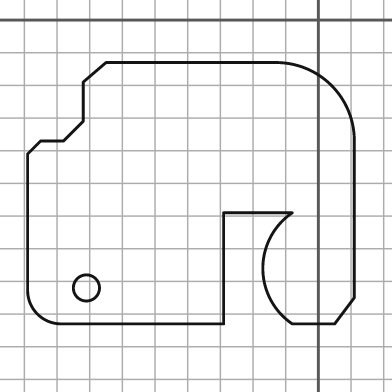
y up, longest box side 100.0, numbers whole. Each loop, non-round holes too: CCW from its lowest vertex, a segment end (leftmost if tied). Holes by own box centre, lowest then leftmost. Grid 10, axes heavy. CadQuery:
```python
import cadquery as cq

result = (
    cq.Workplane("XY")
    .moveTo(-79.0, -93.0)
    .lineTo(-29.0, -93.0)
    .lineTo(-29.0, -59.0)
    .lineTo(-8.0, -59.0)
    .threePointArc((-17.0, -76.0), (-8.0, -93.0))
    .lineTo(5.0, -93.0)
    .lineTo(11.0, -85.0)
    .lineTo(11.0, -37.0)
    .threePointArc((4.0, -20.0), (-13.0, -13.0))
    .lineTo(-65.0, -13.0)
    .lineTo(-72.0, -19.0)
    .lineTo(-72.0, -31.0)
    .lineTo(-78.0, -37.0)
    .lineTo(-85.0, -37.0)
    .lineTo(-89.0, -41.0)
    .lineTo(-89.0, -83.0)
    .threePointArc((-86.0, -90.0), (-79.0, -93.0))
    .close()
    .moveTo(-71.0, -82.0)
    .circle(4.0)
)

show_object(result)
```